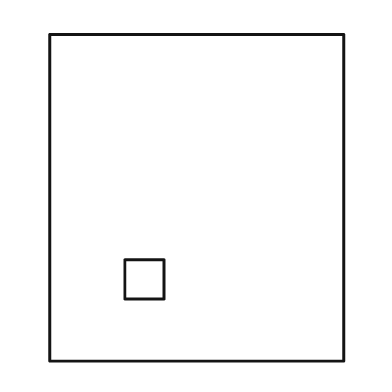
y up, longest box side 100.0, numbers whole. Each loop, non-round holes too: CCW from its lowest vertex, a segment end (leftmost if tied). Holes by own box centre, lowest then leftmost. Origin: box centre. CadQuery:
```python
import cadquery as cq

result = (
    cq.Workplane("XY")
    .moveTo(-45.0, -50.0)
    .lineTo(45.0, -50.0)
    .lineTo(45.0, 50.0)
    .lineTo(-45.0, 50.0)
    .close()
    .moveTo(-22.0, -31.0)
    .lineTo(-10.0, -31.0)
    .lineTo(-10.0, -19.0)
    .lineTo(-22.0, -19.0)
    .close()
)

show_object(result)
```